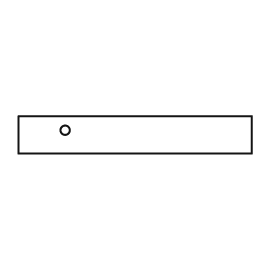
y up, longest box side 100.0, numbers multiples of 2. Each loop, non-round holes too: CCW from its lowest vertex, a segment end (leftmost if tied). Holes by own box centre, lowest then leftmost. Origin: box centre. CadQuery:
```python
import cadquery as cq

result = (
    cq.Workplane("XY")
    .moveTo(-50.0, -8.0)
    .lineTo(50.0, -8.0)
    .lineTo(50.0, 8.0)
    .lineTo(-50.0, 8.0)
    .close()
    .moveTo(-30.0, 2.0)
    .circle(2.0)
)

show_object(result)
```